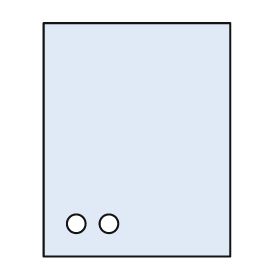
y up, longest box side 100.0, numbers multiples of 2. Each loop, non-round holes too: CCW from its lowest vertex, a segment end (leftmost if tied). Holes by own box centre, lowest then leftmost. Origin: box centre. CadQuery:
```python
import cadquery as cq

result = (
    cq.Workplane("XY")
    .moveTo(-40.0, -50.0)
    .lineTo(40.0, -50.0)
    .lineTo(40.0, 50.0)
    .lineTo(-40.0, 50.0)
    .close()
    .moveTo(-26.0, -36.0)
    .circle(4.0)
    .moveTo(-12.0, -36.0)
    .circle(4.0)
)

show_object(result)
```